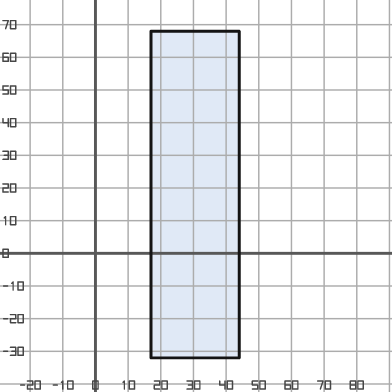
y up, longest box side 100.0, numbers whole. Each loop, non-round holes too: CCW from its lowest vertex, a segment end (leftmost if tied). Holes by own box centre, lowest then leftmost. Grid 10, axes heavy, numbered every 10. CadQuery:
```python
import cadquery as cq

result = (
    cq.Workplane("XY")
    .moveTo(17.0, -32.0)
    .lineTo(44.0, -32.0)
    .lineTo(44.0, 68.0)
    .lineTo(17.0, 68.0)
    .close()
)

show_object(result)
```